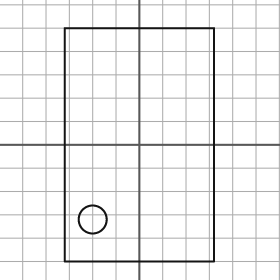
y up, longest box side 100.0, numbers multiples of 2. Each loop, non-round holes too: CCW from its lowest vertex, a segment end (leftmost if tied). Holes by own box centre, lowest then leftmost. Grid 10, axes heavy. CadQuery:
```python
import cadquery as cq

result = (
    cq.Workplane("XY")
    .moveTo(-32.0, -50.0)
    .lineTo(32.0, -50.0)
    .lineTo(32.0, 50.0)
    .lineTo(-32.0, 50.0)
    .close()
    .moveTo(-20.0, -32.0)
    .circle(6.0)
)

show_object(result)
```